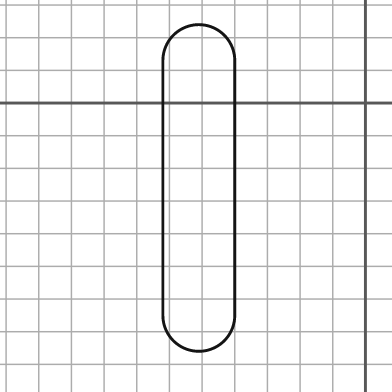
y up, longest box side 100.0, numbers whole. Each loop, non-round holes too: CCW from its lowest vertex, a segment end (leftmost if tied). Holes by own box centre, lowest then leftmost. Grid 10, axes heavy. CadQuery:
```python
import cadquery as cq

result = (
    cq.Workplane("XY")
    .moveTo(-62.0, -65.0)
    .threePointArc((-51.0, -76.0), (-40.0, -65.0))
    .lineTo(-40.0, 13.0)
    .threePointArc((-51.0, 24.0), (-62.0, 13.0))
    .close()
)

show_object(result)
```